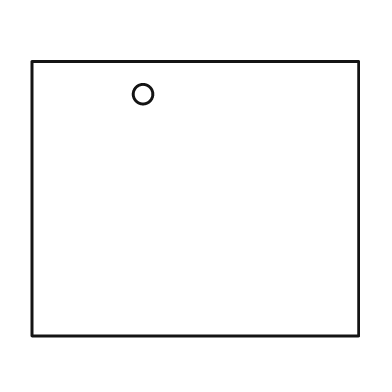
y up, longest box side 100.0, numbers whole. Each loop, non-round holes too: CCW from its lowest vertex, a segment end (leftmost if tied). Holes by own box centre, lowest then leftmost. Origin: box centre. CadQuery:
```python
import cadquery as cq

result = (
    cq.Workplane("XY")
    .moveTo(-50.0, -42.0)
    .lineTo(50.0, -42.0)
    .lineTo(50.0, 42.0)
    .lineTo(-50.0, 42.0)
    .close()
    .moveTo(-16.0, 32.0)
    .circle(3.0)
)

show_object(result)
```